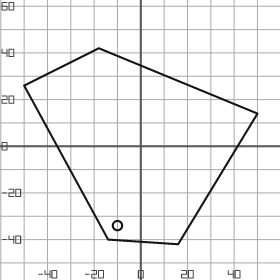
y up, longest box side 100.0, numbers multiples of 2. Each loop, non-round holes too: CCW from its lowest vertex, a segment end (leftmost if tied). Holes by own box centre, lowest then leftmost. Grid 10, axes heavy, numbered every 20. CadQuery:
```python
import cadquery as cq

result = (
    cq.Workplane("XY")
    .moveTo(16.0, -42.0)
    .lineTo(50.0, 14.0)
    .lineTo(-18.0, 42.0)
    .lineTo(-50.0, 26.0)
    .lineTo(-14.0, -40.0)
    .close()
    .moveTo(-10.0, -34.0)
    .circle(2.0)
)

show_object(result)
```